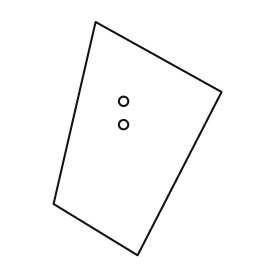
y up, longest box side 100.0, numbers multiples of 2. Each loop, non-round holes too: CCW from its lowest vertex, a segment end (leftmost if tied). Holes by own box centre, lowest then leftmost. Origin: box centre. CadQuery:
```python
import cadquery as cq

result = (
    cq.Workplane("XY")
    .moveTo(0.0, -50.0)
    .lineTo(36.0, 20.0)
    .lineTo(-18.0, 50.0)
    .lineTo(-36.0, -28.0)
    .close()
    .moveTo(-6.0, 6.0)
    .circle(2.0)
    .moveTo(-6.0, 16.0)
    .circle(2.0)
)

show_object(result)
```